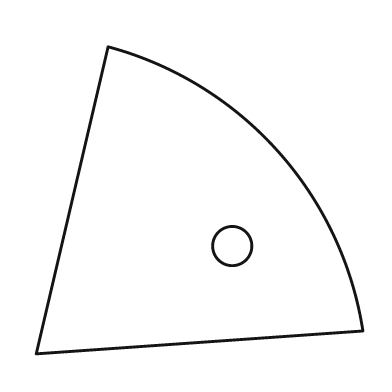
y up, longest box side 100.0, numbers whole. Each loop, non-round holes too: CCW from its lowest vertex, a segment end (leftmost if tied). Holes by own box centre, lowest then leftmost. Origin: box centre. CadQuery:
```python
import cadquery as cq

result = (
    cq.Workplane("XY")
    .moveTo(-50.0, -47.0)
    .lineTo(50.0, -40.0)
    .threePointArc((24.0, 15.0), (-28.0, 47.0))
    .close()
    .moveTo(10.0, -14.0)
    .circle(6.0)
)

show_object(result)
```